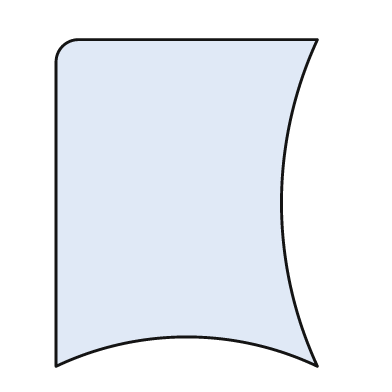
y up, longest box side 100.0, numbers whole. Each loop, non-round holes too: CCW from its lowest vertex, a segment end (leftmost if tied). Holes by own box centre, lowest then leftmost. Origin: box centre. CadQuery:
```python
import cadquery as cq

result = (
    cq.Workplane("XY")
    .moveTo(-40.0, -50.0)
    .threePointArc((0.0, -41.0), (40.0, -50.0))
    .threePointArc((29.0, 0.0), (40.0, 50.0))
    .lineTo(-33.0, 50.0)
    .threePointArc((-38.0, 48.0), (-40.0, 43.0))
    .close()
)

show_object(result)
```